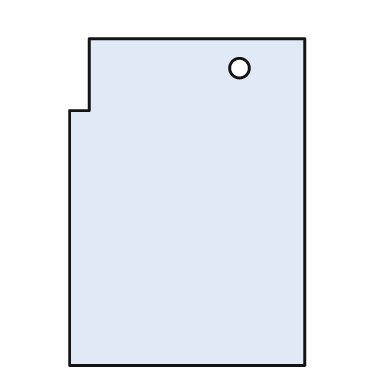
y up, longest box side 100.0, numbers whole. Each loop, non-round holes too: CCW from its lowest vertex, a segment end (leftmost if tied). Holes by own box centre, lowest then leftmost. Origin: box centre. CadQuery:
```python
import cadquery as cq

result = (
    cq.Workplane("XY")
    .moveTo(-36.0, -50.0)
    .lineTo(36.0, -50.0)
    .lineTo(36.0, 50.0)
    .lineTo(-30.0, 50.0)
    .lineTo(-30.0, 28.0)
    .lineTo(-36.0, 28.0)
    .close()
    .moveTo(16.0, 41.0)
    .circle(3.0)
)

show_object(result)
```